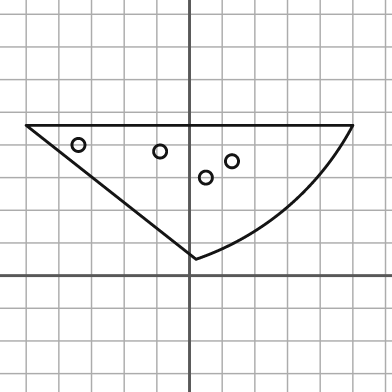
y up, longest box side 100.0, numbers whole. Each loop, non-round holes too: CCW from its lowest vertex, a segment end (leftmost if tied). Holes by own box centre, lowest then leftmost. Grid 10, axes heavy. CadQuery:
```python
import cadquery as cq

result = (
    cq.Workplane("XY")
    .moveTo(2.0, 5.0)
    .threePointArc((30.0, 21.0), (50.0, 46.0))
    .lineTo(-50.0, 46.0)
    .close()
    .moveTo(5.0, 30.0)
    .circle(2.0)
    .moveTo(13.0, 35.0)
    .circle(2.0)
    .moveTo(-9.0, 38.0)
    .circle(2.0)
    .moveTo(-34.0, 40.0)
    .circle(2.0)
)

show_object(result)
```